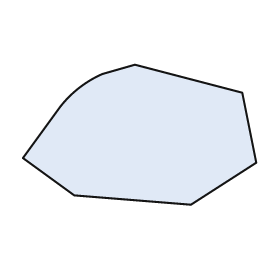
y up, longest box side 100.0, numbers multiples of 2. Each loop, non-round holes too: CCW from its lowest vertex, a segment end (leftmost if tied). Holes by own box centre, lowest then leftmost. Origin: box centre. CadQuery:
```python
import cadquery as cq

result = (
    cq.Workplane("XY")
    .moveTo(22.0, -30.0)
    .lineTo(50.0, -12.0)
    .lineTo(44.0, 18.0)
    .lineTo(-2.0, 30.0)
    .lineTo(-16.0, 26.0)
    .threePointArc((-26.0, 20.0), (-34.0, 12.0))
    .lineTo(-50.0, -10.0)
    .lineTo(-28.0, -26.0)
    .close()
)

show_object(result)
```